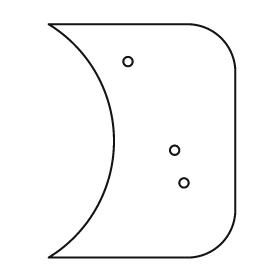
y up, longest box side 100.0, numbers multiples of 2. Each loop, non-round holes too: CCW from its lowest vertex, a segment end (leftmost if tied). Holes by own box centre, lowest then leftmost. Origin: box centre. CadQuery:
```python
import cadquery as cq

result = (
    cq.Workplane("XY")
    .moveTo(-40.0, -50.0)
    .lineTo(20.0, -50.0)
    .threePointArc((34.0, -44.0), (40.0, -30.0))
    .lineTo(40.0, 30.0)
    .threePointArc((34.0, 44.0), (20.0, 50.0))
    .lineTo(-40.0, 50.0)
    .threePointArc((-12.0, 0.0), (-40.0, -50.0))
    .close()
    .moveTo(18.0, -18.0)
    .circle(2.0)
    .moveTo(14.0, -4.0)
    .circle(2.0)
    .moveTo(-6.0, 34.0)
    .circle(2.0)
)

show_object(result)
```